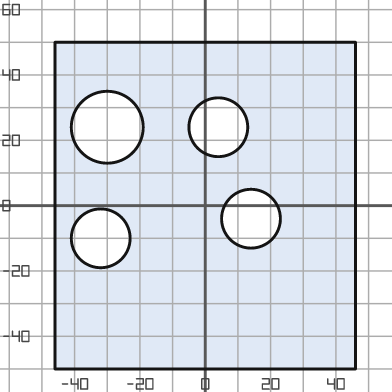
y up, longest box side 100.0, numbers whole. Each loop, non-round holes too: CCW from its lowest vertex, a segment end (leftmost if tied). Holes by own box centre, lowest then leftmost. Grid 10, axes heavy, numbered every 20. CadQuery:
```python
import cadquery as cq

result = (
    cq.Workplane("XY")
    .moveTo(-46.0, -50.0)
    .lineTo(46.0, -50.0)
    .lineTo(46.0, 50.0)
    .lineTo(-46.0, 50.0)
    .close()
    .moveTo(-32.0, -10.0)
    .circle(9.0)
    .moveTo(14.0, -4.0)
    .circle(9.0)
    .moveTo(-30.0, 24.0)
    .circle(11.0)
    .moveTo(4.0, 24.0)
    .circle(9.0)
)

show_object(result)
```